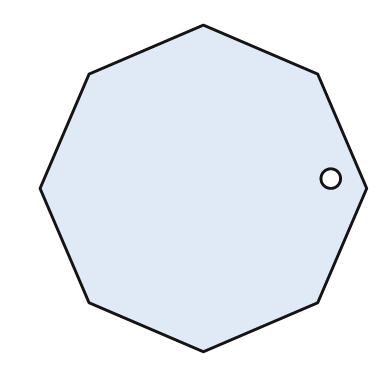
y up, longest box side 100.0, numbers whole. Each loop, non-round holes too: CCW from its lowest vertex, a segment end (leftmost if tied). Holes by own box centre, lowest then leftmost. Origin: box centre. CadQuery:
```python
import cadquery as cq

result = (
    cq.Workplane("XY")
    .moveTo(0.0, -50.0)
    .lineTo(35.0, -35.0)
    .lineTo(50.0, 0.0)
    .lineTo(35.0, 35.0)
    .lineTo(0.0, 50.0)
    .lineTo(-35.0, 35.0)
    .lineTo(-50.0, 0.0)
    .lineTo(-35.0, -35.0)
    .close()
    .moveTo(39.0, 3.0)
    .circle(3.0)
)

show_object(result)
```